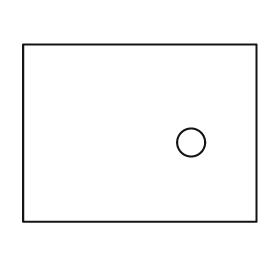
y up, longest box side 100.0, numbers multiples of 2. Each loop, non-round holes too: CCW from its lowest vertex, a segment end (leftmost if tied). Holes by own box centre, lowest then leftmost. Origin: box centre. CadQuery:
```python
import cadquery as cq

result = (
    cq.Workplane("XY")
    .moveTo(-50.0, -38.0)
    .lineTo(50.0, -38.0)
    .lineTo(50.0, 38.0)
    .lineTo(-50.0, 38.0)
    .close()
    .moveTo(22.0, -4.0)
    .circle(6.0)
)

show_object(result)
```